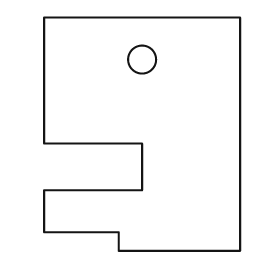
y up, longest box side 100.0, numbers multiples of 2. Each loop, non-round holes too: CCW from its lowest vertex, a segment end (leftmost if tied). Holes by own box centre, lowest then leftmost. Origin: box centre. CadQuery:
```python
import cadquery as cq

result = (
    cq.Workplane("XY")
    .moveTo(-10.0, -50.0)
    .lineTo(42.0, -50.0)
    .lineTo(42.0, 50.0)
    .lineTo(-42.0, 50.0)
    .lineTo(-42.0, -4.0)
    .lineTo(0.0, -4.0)
    .lineTo(0.0, -24.0)
    .lineTo(-42.0, -24.0)
    .lineTo(-42.0, -42.0)
    .lineTo(-10.0, -42.0)
    .close()
    .moveTo(0.0, 32.0)
    .circle(6.0)
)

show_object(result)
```